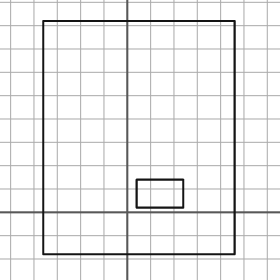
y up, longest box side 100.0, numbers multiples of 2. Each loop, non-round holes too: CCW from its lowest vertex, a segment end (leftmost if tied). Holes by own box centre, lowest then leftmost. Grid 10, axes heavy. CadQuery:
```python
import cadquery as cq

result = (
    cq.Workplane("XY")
    .moveTo(-36.0, -18.0)
    .lineTo(46.0, -18.0)
    .lineTo(46.0, 82.0)
    .lineTo(-36.0, 82.0)
    .close()
    .moveTo(4.0, 2.0)
    .lineTo(24.0, 2.0)
    .lineTo(24.0, 14.0)
    .lineTo(4.0, 14.0)
    .close()
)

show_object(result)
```